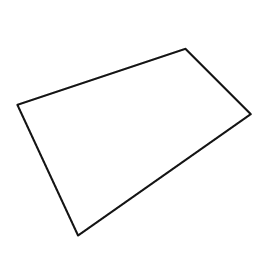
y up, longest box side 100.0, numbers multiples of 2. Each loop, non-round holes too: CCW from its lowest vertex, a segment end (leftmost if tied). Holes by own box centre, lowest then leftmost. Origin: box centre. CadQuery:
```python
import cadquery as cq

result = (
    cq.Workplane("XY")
    .moveTo(-24.0, -40.0)
    .lineTo(50.0, 12.0)
    .lineTo(22.0, 40.0)
    .lineTo(-50.0, 16.0)
    .close()
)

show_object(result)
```